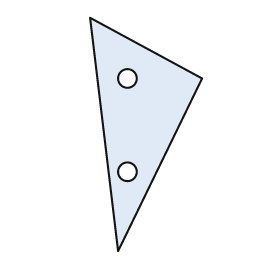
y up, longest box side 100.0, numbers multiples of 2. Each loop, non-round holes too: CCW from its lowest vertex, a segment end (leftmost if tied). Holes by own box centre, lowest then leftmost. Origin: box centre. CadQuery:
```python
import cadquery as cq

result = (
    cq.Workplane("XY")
    .moveTo(-12.0, -50.0)
    .lineTo(24.0, 24.0)
    .lineTo(-24.0, 50.0)
    .close()
    .moveTo(-8.0, -16.0)
    .circle(4.0)
    .moveTo(-8.0, 24.0)
    .circle(4.0)
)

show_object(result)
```